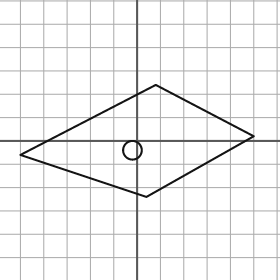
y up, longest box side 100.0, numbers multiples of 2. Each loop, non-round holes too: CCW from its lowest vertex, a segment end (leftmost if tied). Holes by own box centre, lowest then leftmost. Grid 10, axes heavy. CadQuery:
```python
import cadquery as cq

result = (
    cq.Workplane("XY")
    .moveTo(4.0, -24.0)
    .lineTo(50.0, 2.0)
    .lineTo(8.0, 24.0)
    .lineTo(-50.0, -6.0)
    .close()
    .moveTo(-2.0, -4.0)
    .circle(4.0)
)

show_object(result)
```